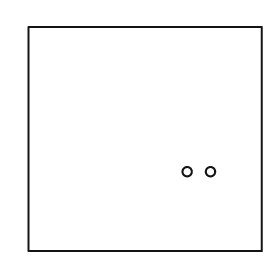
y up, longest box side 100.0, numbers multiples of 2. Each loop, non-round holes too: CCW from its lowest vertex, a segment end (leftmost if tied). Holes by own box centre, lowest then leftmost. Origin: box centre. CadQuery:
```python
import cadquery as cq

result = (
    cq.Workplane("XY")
    .moveTo(-50.0, -48.0)
    .lineTo(50.0, -48.0)
    .lineTo(50.0, 48.0)
    .lineTo(-50.0, 48.0)
    .close()
    .moveTo(18.0, -14.0)
    .circle(2.0)
    .moveTo(28.0, -14.0)
    .circle(2.0)
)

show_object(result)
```